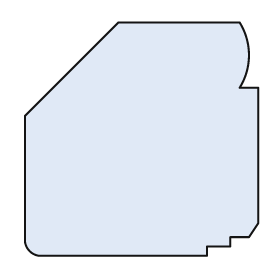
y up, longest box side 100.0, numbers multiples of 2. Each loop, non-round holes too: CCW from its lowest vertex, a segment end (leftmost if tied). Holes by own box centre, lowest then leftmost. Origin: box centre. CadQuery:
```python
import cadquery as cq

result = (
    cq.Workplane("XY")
    .moveTo(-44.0, -50.0)
    .lineTo(28.0, -50.0)
    .lineTo(28.0, -46.0)
    .lineTo(38.0, -46.0)
    .lineTo(38.0, -42.0)
    .lineTo(46.0, -42.0)
    .lineTo(50.0, -36.0)
    .lineTo(50.0, 22.0)
    .lineTo(42.0, 22.0)
    .threePointArc((46.0, 36.0), (42.0, 50.0))
    .lineTo(-10.0, 50.0)
    .lineTo(-50.0, 10.0)
    .lineTo(-50.0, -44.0)
    .threePointArc((-48.0, -48.0), (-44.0, -50.0))
    .close()
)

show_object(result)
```